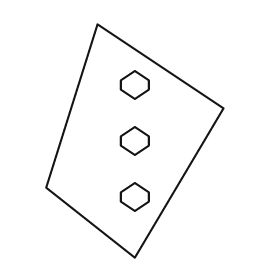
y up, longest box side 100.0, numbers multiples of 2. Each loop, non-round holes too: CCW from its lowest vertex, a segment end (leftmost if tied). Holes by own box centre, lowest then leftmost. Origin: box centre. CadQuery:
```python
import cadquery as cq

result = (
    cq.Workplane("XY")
    .moveTo(0.0, -50.0)
    .lineTo(38.0, 14.0)
    .lineTo(-16.0, 50.0)
    .lineTo(-38.0, -20.0)
    .close()
    .moveTo(0.0, -30.0)
    .lineTo(6.0, -26.0)
    .lineTo(6.0, -22.0)
    .lineTo(0.0, -18.0)
    .lineTo(-6.0, -22.0)
    .lineTo(-6.0, -26.0)
    .close()
    .moveTo(0.0, -6.0)
    .lineTo(6.0, -2.0)
    .lineTo(6.0, 2.0)
    .lineTo(0.0, 6.0)
    .lineTo(-6.0, 2.0)
    .lineTo(-6.0, -2.0)
    .close()
    .moveTo(0.0, 18.0)
    .lineTo(6.0, 22.0)
    .lineTo(6.0, 26.0)
    .lineTo(0.0, 30.0)
    .lineTo(-6.0, 26.0)
    .lineTo(-6.0, 22.0)
    .close()
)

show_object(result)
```